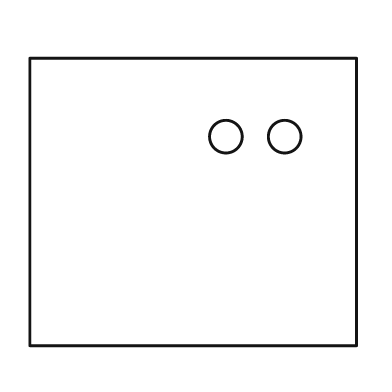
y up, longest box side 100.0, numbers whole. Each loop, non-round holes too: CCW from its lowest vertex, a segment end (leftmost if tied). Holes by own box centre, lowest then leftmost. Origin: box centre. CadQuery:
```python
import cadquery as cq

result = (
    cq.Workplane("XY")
    .moveTo(-50.0, -44.0)
    .lineTo(50.0, -44.0)
    .lineTo(50.0, 44.0)
    .lineTo(-50.0, 44.0)
    .close()
    .moveTo(10.0, 20.0)
    .circle(5.0)
    .moveTo(28.0, 20.0)
    .circle(5.0)
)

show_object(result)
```